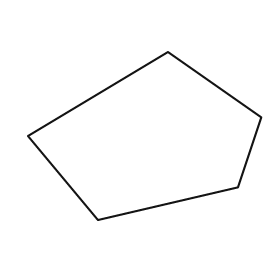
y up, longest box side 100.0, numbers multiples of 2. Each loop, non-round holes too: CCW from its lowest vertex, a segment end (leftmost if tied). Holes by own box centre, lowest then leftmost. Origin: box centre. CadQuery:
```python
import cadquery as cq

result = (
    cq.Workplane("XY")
    .moveTo(-20.0, -36.0)
    .lineTo(40.0, -22.0)
    .lineTo(50.0, 8.0)
    .lineTo(10.0, 36.0)
    .lineTo(-50.0, 0.0)
    .close()
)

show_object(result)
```